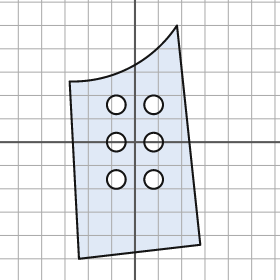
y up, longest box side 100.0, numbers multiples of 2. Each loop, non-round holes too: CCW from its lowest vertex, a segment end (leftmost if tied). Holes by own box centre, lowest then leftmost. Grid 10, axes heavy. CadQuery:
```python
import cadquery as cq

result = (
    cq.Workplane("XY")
    .moveTo(-24.0, -50.0)
    .lineTo(28.0, -44.0)
    .lineTo(18.0, 50.0)
    .threePointArc((-2.0, 32.0), (-28.0, 26.0))
    .close()
    .moveTo(-8.0, -16.0)
    .circle(4.0)
    .moveTo(8.0, -16.0)
    .circle(4.0)
    .moveTo(-8.0, 0.0)
    .circle(4.0)
    .moveTo(8.0, 0.0)
    .circle(4.0)
    .moveTo(-8.0, 16.0)
    .circle(4.0)
    .moveTo(8.0, 16.0)
    .circle(4.0)
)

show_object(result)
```